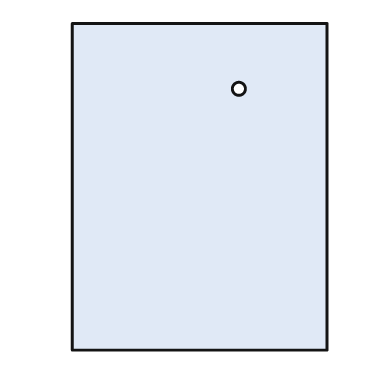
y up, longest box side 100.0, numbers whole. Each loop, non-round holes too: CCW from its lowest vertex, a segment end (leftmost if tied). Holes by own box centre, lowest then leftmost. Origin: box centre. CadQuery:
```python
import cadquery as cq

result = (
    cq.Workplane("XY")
    .moveTo(-39.0, -50.0)
    .lineTo(39.0, -50.0)
    .lineTo(39.0, 50.0)
    .lineTo(-39.0, 50.0)
    .close()
    .moveTo(12.0, 30.0)
    .circle(2.0)
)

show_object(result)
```